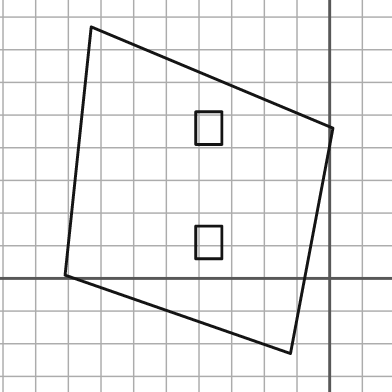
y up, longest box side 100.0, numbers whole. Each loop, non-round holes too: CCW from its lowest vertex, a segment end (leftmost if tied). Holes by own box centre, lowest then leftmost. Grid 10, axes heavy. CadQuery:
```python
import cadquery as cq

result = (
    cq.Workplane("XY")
    .moveTo(-12.0, -23.0)
    .lineTo(1.0, 46.0)
    .lineTo(-73.0, 77.0)
    .lineTo(-81.0, 1.0)
    .close()
    .moveTo(-41.0, 6.0)
    .lineTo(-33.0, 6.0)
    .lineTo(-33.0, 16.0)
    .lineTo(-41.0, 16.0)
    .close()
    .moveTo(-41.0, 41.0)
    .lineTo(-33.0, 41.0)
    .lineTo(-33.0, 51.0)
    .lineTo(-41.0, 51.0)
    .close()
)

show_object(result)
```